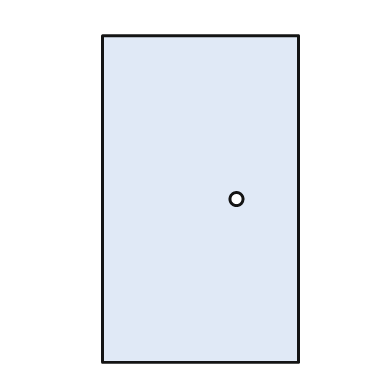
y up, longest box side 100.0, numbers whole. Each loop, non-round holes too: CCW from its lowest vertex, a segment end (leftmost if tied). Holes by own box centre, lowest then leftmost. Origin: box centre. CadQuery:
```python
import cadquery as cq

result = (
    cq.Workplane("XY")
    .moveTo(-30.0, -50.0)
    .lineTo(30.0, -50.0)
    .lineTo(30.0, 50.0)
    .lineTo(-30.0, 50.0)
    .close()
    .moveTo(11.0, 0.0)
    .circle(2.0)
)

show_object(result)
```